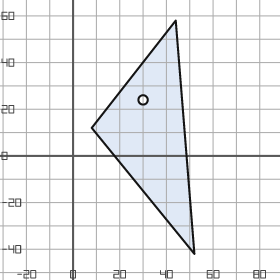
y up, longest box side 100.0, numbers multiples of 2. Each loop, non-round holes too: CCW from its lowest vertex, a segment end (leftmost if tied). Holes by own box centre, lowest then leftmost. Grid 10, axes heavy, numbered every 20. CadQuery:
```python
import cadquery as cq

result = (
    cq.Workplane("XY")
    .moveTo(52.0, -42.0)
    .lineTo(44.0, 58.0)
    .lineTo(8.0, 12.0)
    .close()
    .moveTo(30.0, 24.0)
    .circle(2.0)
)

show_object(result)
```